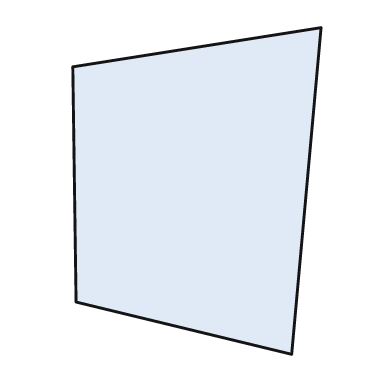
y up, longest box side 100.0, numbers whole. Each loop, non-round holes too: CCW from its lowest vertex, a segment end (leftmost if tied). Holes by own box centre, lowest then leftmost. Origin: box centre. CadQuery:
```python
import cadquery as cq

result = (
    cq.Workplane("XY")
    .moveTo(29.0, -50.0)
    .lineTo(38.0, 50.0)
    .lineTo(-38.0, 38.0)
    .lineTo(-37.0, -34.0)
    .close()
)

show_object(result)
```